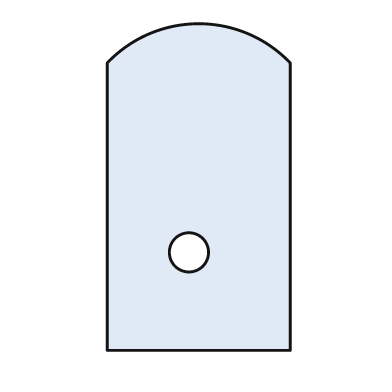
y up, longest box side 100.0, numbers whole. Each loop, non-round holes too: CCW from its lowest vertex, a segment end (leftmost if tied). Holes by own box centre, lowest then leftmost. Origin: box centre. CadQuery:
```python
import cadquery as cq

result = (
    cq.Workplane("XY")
    .moveTo(-28.0, -50.0)
    .lineTo(28.0, -50.0)
    .lineTo(28.0, 38.0)
    .threePointArc((0.0, 50.0), (-28.0, 38.0))
    .close()
    .moveTo(-3.0, -20.0)
    .circle(6.0)
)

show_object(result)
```